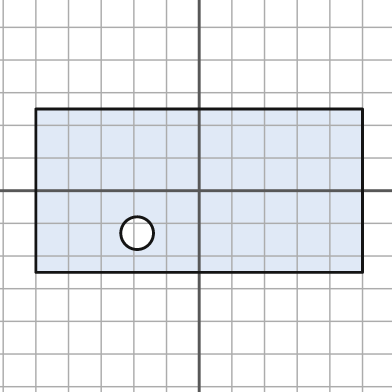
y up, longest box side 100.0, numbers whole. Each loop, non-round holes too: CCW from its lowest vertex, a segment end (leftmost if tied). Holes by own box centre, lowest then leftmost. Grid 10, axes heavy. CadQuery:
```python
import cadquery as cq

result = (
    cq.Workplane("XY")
    .moveTo(-50.0, -25.0)
    .lineTo(50.0, -25.0)
    .lineTo(50.0, 25.0)
    .lineTo(-50.0, 25.0)
    .close()
    .moveTo(-19.0, -13.0)
    .circle(5.0)
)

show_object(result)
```